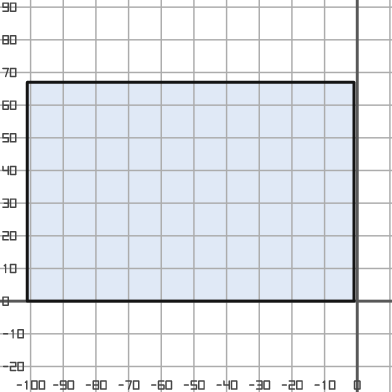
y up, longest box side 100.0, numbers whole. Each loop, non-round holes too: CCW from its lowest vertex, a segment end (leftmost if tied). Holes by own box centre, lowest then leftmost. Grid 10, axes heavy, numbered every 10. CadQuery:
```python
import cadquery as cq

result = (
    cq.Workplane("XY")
    .moveTo(-101.0, 0.0)
    .lineTo(-1.0, 0.0)
    .lineTo(-1.0, 67.0)
    .lineTo(-101.0, 67.0)
    .close()
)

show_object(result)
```